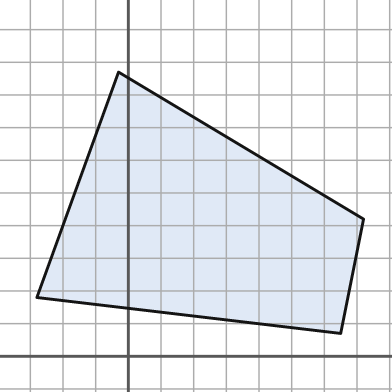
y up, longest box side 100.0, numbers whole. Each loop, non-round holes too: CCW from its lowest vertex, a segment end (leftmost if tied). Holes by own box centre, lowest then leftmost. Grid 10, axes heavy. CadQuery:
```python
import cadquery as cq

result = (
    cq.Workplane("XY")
    .moveTo(65.0, 7.0)
    .lineTo(72.0, 42.0)
    .lineTo(-3.0, 87.0)
    .lineTo(-28.0, 18.0)
    .close()
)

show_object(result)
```